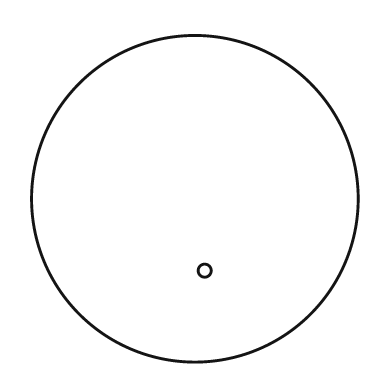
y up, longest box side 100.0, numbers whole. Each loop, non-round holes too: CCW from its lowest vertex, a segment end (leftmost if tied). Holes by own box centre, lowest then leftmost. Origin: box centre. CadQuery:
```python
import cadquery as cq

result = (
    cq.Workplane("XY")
    .moveTo(0.0, 0.0)
    .circle(50.0)
    .moveTo(3.0, -22.0)
    .circle(2.0)
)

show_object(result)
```